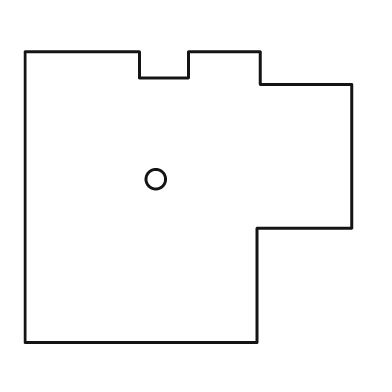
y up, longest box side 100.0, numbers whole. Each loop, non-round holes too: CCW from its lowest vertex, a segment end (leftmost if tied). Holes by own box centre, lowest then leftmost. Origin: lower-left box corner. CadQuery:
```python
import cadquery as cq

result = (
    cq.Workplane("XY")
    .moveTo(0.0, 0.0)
    .lineTo(71.0, 0.0)
    .lineTo(71.0, 35.0)
    .lineTo(100.0, 35.0)
    .lineTo(100.0, 79.0)
    .lineTo(72.0, 79.0)
    .lineTo(72.0, 89.0)
    .lineTo(50.0, 89.0)
    .lineTo(50.0, 81.0)
    .lineTo(35.0, 81.0)
    .lineTo(35.0, 89.0)
    .lineTo(0.0, 89.0)
    .close()
    .moveTo(40.0, 50.0)
    .circle(3.0)
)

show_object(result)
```